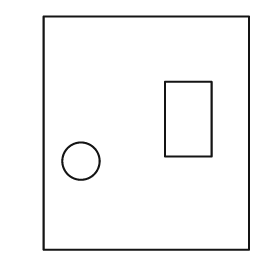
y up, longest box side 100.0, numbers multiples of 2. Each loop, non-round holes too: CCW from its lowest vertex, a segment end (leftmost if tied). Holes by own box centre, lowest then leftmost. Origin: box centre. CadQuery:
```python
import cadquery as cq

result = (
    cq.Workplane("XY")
    .moveTo(-44.0, -50.0)
    .lineTo(44.0, -50.0)
    .lineTo(44.0, 50.0)
    .lineTo(-44.0, 50.0)
    .close()
    .moveTo(-28.0, -12.0)
    .circle(8.0)
    .moveTo(8.0, -10.0)
    .lineTo(28.0, -10.0)
    .lineTo(28.0, 22.0)
    .lineTo(8.0, 22.0)
    .close()
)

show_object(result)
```